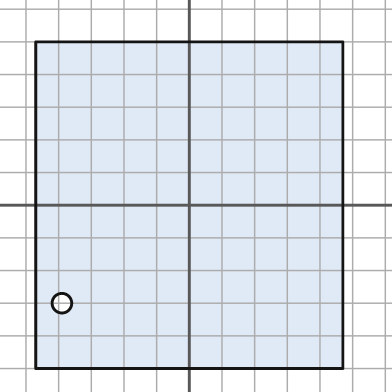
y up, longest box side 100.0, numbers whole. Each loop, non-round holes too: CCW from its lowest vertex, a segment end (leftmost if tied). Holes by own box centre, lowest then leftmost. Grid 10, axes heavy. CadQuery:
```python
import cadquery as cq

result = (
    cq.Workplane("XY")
    .moveTo(-47.0, -50.0)
    .lineTo(47.0, -50.0)
    .lineTo(47.0, 50.0)
    .lineTo(-47.0, 50.0)
    .close()
    .moveTo(-39.0, -30.0)
    .circle(3.0)
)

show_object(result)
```